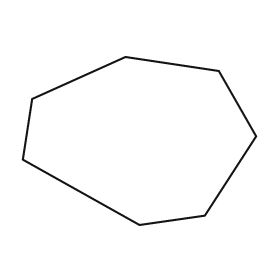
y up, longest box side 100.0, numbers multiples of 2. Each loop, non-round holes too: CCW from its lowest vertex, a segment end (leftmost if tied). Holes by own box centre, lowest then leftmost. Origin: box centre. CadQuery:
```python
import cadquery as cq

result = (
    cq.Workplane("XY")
    .moveTo(0.0, -36.0)
    .lineTo(28.0, -32.0)
    .lineTo(50.0, 2.0)
    .lineTo(34.0, 30.0)
    .lineTo(-6.0, 36.0)
    .lineTo(-46.0, 18.0)
    .lineTo(-50.0, -8.0)
    .close()
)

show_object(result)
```